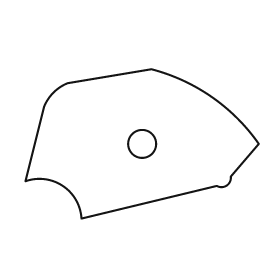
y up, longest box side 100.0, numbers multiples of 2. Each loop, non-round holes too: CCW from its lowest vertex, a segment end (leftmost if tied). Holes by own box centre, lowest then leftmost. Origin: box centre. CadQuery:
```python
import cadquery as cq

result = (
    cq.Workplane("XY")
    .moveTo(-26.0, -32.0)
    .lineTo(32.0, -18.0)
    .threePointArc((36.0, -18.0), (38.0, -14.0))
    .lineTo(50.0, 0.0)
    .threePointArc((30.0, 20.0), (4.0, 32.0))
    .lineTo(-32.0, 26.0)
    .threePointArc((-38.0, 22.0), (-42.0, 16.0))
    .lineTo(-50.0, -16.0)
    .threePointArc((-34.0, -18.0), (-26.0, -32.0))
    .close()
    .moveTo(0.0, 0.0)
    .circle(6.0)
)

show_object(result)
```